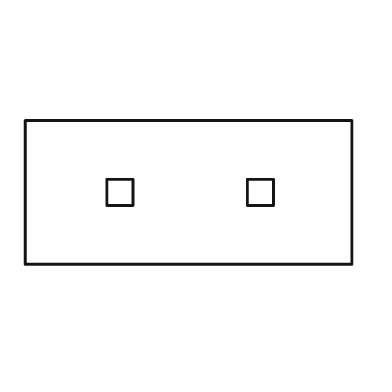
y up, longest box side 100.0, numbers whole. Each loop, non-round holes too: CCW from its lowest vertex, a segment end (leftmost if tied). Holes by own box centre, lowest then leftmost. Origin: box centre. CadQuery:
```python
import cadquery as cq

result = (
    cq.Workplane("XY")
    .moveTo(-50.0, -22.0)
    .lineTo(50.0, -22.0)
    .lineTo(50.0, 22.0)
    .lineTo(-50.0, 22.0)
    .close()
    .moveTo(-25.0, -4.0)
    .lineTo(-17.0, -4.0)
    .lineTo(-17.0, 4.0)
    .lineTo(-25.0, 4.0)
    .close()
    .moveTo(18.0, -4.0)
    .lineTo(26.0, -4.0)
    .lineTo(26.0, 4.0)
    .lineTo(18.0, 4.0)
    .close()
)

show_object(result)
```